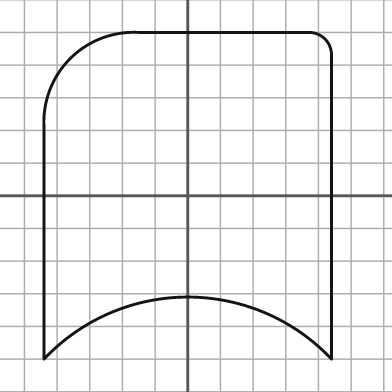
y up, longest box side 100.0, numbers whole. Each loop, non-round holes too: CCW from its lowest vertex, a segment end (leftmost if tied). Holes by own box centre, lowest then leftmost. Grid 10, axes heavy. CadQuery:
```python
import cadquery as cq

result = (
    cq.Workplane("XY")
    .moveTo(-44.0, -50.0)
    .threePointArc((0.0, -31.0), (44.0, -50.0))
    .lineTo(44.0, 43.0)
    .threePointArc((42.0, 48.0), (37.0, 50.0))
    .lineTo(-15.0, 50.0)
    .threePointArc((-36.0, 42.0), (-44.0, 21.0))
    .close()
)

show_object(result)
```